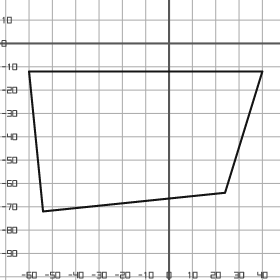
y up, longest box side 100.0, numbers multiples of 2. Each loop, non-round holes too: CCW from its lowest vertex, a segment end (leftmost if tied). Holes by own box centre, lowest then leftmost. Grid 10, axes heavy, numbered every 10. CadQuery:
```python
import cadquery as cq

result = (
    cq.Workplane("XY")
    .moveTo(-54.0, -72.0)
    .lineTo(24.0, -64.0)
    .lineTo(40.0, -12.0)
    .lineTo(-60.0, -12.0)
    .close()
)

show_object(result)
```